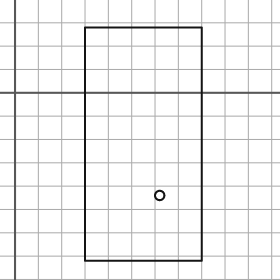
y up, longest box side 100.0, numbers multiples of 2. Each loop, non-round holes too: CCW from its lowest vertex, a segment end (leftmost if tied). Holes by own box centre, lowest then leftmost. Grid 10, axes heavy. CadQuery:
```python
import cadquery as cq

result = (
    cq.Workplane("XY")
    .moveTo(30.0, -72.0)
    .lineTo(80.0, -72.0)
    .lineTo(80.0, 28.0)
    .lineTo(30.0, 28.0)
    .close()
    .moveTo(62.0, -44.0)
    .circle(2.0)
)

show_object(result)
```